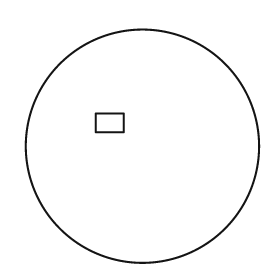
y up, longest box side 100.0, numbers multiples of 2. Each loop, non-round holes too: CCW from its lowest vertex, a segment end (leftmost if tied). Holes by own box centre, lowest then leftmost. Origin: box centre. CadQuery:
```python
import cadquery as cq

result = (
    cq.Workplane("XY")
    .moveTo(0.0, 0.0)
    .circle(50.0)
    .moveTo(-20.0, 6.0)
    .lineTo(-8.0, 6.0)
    .lineTo(-8.0, 14.0)
    .lineTo(-20.0, 14.0)
    .close()
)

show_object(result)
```